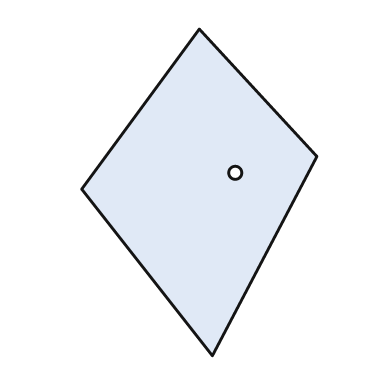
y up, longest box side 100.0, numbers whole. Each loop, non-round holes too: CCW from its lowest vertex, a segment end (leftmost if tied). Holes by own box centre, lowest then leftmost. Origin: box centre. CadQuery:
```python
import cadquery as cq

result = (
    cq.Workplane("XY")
    .moveTo(4.0, -50.0)
    .lineTo(36.0, 11.0)
    .lineTo(0.0, 50.0)
    .lineTo(-36.0, 1.0)
    .close()
    .moveTo(11.0, 6.0)
    .circle(2.0)
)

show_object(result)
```